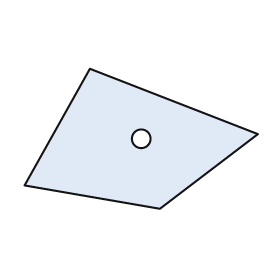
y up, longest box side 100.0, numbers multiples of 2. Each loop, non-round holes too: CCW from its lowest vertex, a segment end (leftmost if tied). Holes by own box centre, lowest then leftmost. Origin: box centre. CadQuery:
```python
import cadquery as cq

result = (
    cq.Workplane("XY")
    .moveTo(8.0, -30.0)
    .lineTo(50.0, 2.0)
    .lineTo(-22.0, 30.0)
    .lineTo(-50.0, -20.0)
    .close()
    .moveTo(0.0, 0.0)
    .circle(4.0)
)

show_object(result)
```